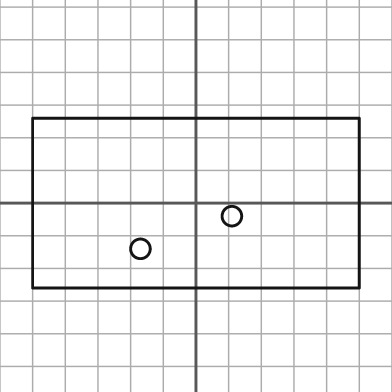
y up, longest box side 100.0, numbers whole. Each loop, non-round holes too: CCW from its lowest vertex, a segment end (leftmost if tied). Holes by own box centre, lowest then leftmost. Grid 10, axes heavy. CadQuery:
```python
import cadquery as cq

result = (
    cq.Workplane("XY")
    .moveTo(-50.0, -26.0)
    .lineTo(50.0, -26.0)
    .lineTo(50.0, 26.0)
    .lineTo(-50.0, 26.0)
    .close()
    .moveTo(-17.0, -14.0)
    .circle(3.0)
    .moveTo(11.0, -4.0)
    .circle(3.0)
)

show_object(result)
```